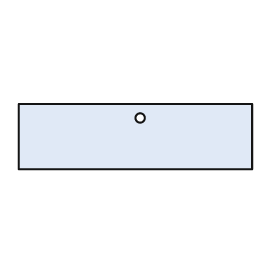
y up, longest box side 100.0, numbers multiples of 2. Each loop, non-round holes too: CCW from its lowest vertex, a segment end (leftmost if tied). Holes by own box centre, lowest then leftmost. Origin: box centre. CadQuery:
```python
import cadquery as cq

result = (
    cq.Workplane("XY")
    .moveTo(-50.0, -14.0)
    .lineTo(50.0, -14.0)
    .lineTo(50.0, 14.0)
    .lineTo(-50.0, 14.0)
    .close()
    .moveTo(2.0, 8.0)
    .circle(2.0)
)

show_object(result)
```